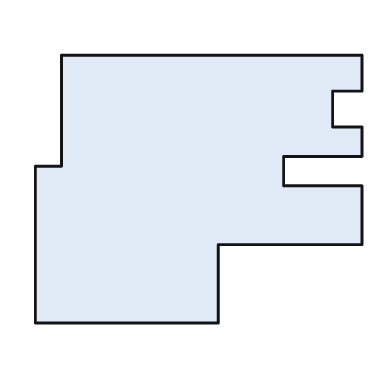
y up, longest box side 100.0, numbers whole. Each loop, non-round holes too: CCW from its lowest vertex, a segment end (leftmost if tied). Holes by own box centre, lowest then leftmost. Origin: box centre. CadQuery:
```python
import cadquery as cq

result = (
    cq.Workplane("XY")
    .moveTo(-50.0, -41.0)
    .lineTo(6.0, -41.0)
    .lineTo(6.0, -17.0)
    .lineTo(50.0, -17.0)
    .lineTo(50.0, 1.0)
    .lineTo(26.0, 1.0)
    .lineTo(26.0, 10.0)
    .lineTo(50.0, 10.0)
    .lineTo(50.0, 19.0)
    .lineTo(41.0, 19.0)
    .lineTo(41.0, 30.0)
    .lineTo(50.0, 30.0)
    .lineTo(50.0, 41.0)
    .lineTo(-42.0, 41.0)
    .lineTo(-42.0, 7.0)
    .lineTo(-50.0, 7.0)
    .close()
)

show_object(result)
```